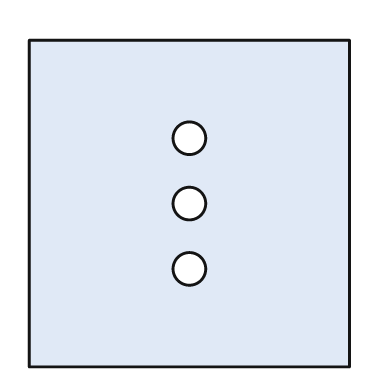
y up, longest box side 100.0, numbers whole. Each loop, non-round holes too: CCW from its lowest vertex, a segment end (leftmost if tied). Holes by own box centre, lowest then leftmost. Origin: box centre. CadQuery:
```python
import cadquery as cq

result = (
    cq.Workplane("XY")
    .moveTo(-49.0, -50.0)
    .lineTo(49.0, -50.0)
    .lineTo(49.0, 50.0)
    .lineTo(-49.0, 50.0)
    .close()
    .moveTo(0.0, -20.0)
    .circle(5.0)
    .moveTo(0.0, 0.0)
    .circle(5.0)
    .moveTo(0.0, 20.0)
    .circle(5.0)
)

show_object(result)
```